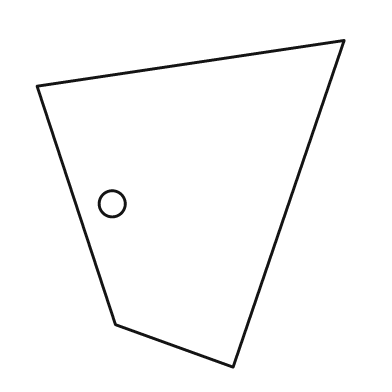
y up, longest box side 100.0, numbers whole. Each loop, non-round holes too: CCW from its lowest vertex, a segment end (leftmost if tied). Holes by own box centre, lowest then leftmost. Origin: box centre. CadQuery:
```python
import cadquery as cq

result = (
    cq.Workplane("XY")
    .moveTo(13.0, -50.0)
    .lineTo(47.0, 50.0)
    .lineTo(-47.0, 36.0)
    .lineTo(-23.0, -37.0)
    .close()
    .moveTo(-24.0, 0.0)
    .circle(4.0)
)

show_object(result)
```